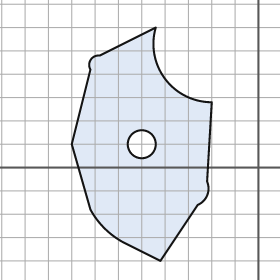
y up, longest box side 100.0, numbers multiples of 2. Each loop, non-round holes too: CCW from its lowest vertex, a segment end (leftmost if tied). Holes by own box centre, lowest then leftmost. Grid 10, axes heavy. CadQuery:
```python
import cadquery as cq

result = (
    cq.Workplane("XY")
    .moveTo(-42.0, -40.0)
    .lineTo(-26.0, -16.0)
    .threePointArc((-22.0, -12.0), (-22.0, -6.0))
    .lineTo(-20.0, 28.0)
    .threePointArc((-40.0, 38.0), (-44.0, 60.0))
    .lineTo(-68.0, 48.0)
    .threePointArc((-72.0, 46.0), (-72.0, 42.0))
    .lineTo(-80.0, 10.0)
    .lineTo(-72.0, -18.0)
    .threePointArc((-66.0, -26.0), (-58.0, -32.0))
    .close()
    .moveTo(-50.0, 10.0)
    .circle(6.0)
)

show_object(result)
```